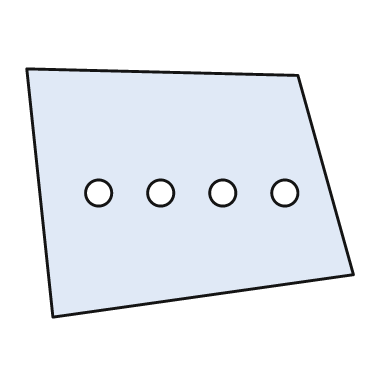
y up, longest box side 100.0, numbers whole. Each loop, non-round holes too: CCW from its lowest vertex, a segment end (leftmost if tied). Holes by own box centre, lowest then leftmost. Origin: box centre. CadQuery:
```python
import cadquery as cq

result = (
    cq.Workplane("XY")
    .moveTo(-42.0, -38.0)
    .lineTo(50.0, -25.0)
    .lineTo(33.0, 36.0)
    .lineTo(-50.0, 38.0)
    .close()
    .moveTo(-28.0, 0.0)
    .circle(4.0)
    .moveTo(-9.0, 0.0)
    .circle(4.0)
    .moveTo(10.0, 0.0)
    .circle(4.0)
    .moveTo(29.0, 0.0)
    .circle(4.0)
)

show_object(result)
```